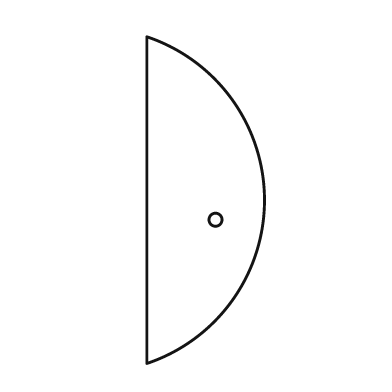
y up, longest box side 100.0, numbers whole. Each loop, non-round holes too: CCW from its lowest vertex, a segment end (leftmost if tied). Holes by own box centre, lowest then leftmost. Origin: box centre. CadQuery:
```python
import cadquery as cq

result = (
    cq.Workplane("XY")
    .moveTo(-18.0, -50.0)
    .threePointArc((18.0, 0.0), (-18.0, 50.0))
    .close()
    .moveTo(3.0, -6.0)
    .circle(2.0)
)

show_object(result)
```